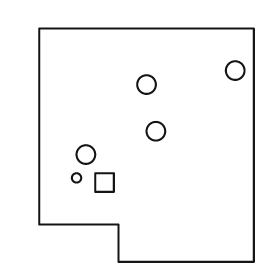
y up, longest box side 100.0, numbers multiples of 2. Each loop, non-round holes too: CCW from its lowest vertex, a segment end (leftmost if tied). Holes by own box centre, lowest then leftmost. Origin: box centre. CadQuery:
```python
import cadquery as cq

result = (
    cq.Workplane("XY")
    .moveTo(-12.0, -50.0)
    .lineTo(46.0, -50.0)
    .lineTo(46.0, 50.0)
    .lineTo(-46.0, 50.0)
    .lineTo(-46.0, -34.0)
    .lineTo(-12.0, -34.0)
    .close()
    .moveTo(-22.0, -20.0)
    .lineTo(-14.0, -20.0)
    .lineTo(-14.0, -12.0)
    .lineTo(-22.0, -12.0)
    .close()
    .moveTo(-30.0, -14.0)
    .circle(2.0)
    .moveTo(-26.0, -4.0)
    .circle(4.0)
    .moveTo(4.0, 6.0)
    .circle(4.0)
    .moveTo(0.0, 26.0)
    .circle(4.0)
    .moveTo(38.0, 32.0)
    .circle(4.0)
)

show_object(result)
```